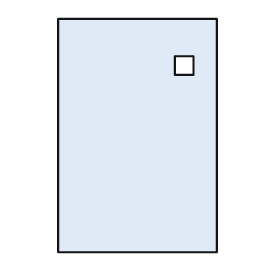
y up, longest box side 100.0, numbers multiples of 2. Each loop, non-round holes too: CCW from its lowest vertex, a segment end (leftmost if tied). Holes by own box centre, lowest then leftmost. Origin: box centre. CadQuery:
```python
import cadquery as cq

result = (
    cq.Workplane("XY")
    .moveTo(-34.0, -50.0)
    .lineTo(34.0, -50.0)
    .lineTo(34.0, 50.0)
    .lineTo(-34.0, 50.0)
    .close()
    .moveTo(16.0, 26.0)
    .lineTo(24.0, 26.0)
    .lineTo(24.0, 34.0)
    .lineTo(16.0, 34.0)
    .close()
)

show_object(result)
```